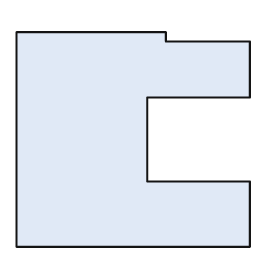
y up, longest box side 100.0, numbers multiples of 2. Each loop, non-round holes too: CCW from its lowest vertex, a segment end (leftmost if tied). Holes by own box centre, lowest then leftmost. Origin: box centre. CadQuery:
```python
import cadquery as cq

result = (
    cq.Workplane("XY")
    .moveTo(-50.0, -46.0)
    .lineTo(50.0, -46.0)
    .lineTo(50.0, -18.0)
    .lineTo(6.0, -18.0)
    .lineTo(6.0, 18.0)
    .lineTo(50.0, 18.0)
    .lineTo(50.0, 42.0)
    .lineTo(14.0, 42.0)
    .lineTo(14.0, 46.0)
    .lineTo(-50.0, 46.0)
    .close()
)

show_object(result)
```